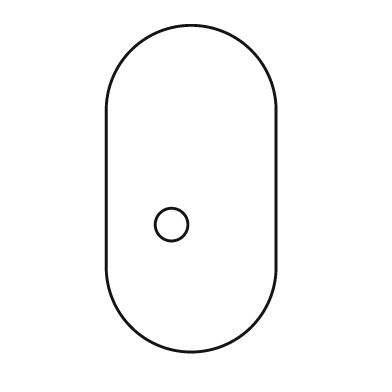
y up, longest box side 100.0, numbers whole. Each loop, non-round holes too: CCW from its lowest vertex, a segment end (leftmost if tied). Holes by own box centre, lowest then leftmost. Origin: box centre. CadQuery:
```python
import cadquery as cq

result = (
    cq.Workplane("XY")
    .moveTo(-26.0, -24.0)
    .threePointArc((0.0, -50.0), (26.0, -24.0))
    .lineTo(26.0, 24.0)
    .threePointArc((0.0, 50.0), (-26.0, 24.0))
    .close()
    .moveTo(-6.0, -11.0)
    .circle(5.0)
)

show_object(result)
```